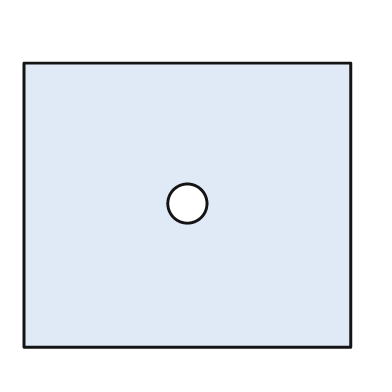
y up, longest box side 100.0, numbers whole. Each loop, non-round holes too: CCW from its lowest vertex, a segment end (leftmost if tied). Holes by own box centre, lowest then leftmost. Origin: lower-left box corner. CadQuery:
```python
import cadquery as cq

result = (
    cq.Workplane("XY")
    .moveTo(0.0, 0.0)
    .lineTo(100.0, 0.0)
    .lineTo(100.0, 87.0)
    .lineTo(0.0, 87.0)
    .close()
    .moveTo(50.0, 44.0)
    .circle(6.0)
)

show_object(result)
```